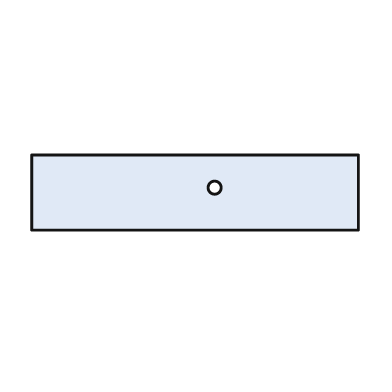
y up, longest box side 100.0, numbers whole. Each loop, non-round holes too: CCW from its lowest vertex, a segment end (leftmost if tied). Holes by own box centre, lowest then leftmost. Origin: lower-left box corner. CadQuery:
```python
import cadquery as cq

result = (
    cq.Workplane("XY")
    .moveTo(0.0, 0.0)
    .lineTo(100.0, 0.0)
    .lineTo(100.0, 23.0)
    .lineTo(0.0, 23.0)
    .close()
    .moveTo(56.0, 13.0)
    .circle(2.0)
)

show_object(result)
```